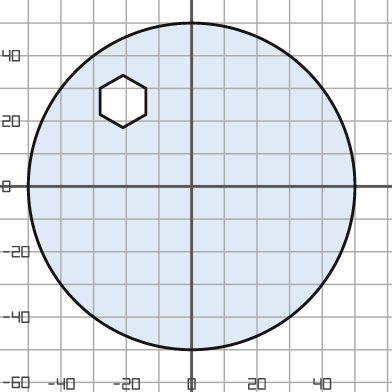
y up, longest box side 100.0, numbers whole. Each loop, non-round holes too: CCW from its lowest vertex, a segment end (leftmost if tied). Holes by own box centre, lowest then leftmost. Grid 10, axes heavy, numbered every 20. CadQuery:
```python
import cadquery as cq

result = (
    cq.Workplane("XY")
    .moveTo(0.0, 0.0)
    .circle(50.0)
    .moveTo(-21.0, 18.0)
    .lineTo(-14.0, 22.0)
    .lineTo(-14.0, 30.0)
    .lineTo(-21.0, 34.0)
    .lineTo(-28.0, 30.0)
    .lineTo(-28.0, 22.0)
    .close()
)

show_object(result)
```